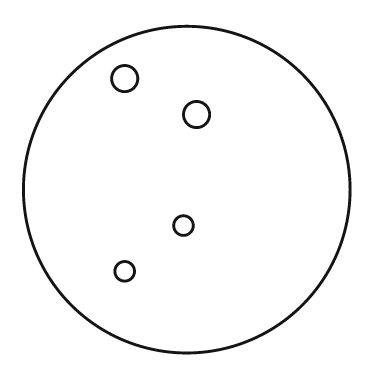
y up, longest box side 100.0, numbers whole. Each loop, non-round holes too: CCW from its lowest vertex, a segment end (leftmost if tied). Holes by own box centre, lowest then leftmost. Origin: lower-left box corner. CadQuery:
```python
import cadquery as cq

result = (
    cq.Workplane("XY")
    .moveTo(50.0, 50.0)
    .circle(50.0)
    .moveTo(31.0, 25.0)
    .circle(3.0)
    .moveTo(49.0, 39.0)
    .circle(3.0)
    .moveTo(53.0, 73.0)
    .circle(4.0)
    .moveTo(31.0, 84.0)
    .circle(4.0)
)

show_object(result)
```